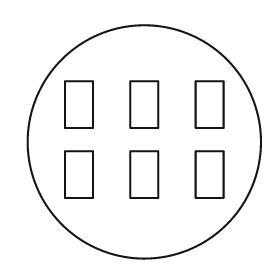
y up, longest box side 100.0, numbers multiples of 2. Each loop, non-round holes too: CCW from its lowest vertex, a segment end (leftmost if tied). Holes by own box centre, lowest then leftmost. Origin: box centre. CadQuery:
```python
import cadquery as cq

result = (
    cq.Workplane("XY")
    .moveTo(0.0, 0.0)
    .circle(50.0)
    .moveTo(-34.0, -24.0)
    .lineTo(-22.0, -24.0)
    .lineTo(-22.0, -4.0)
    .lineTo(-34.0, -4.0)
    .close()
    .moveTo(-6.0, -24.0)
    .lineTo(6.0, -24.0)
    .lineTo(6.0, -4.0)
    .lineTo(-6.0, -4.0)
    .close()
    .moveTo(22.0, -24.0)
    .lineTo(34.0, -24.0)
    .lineTo(34.0, -4.0)
    .lineTo(22.0, -4.0)
    .close()
    .moveTo(-34.0, 6.0)
    .lineTo(-22.0, 6.0)
    .lineTo(-22.0, 26.0)
    .lineTo(-34.0, 26.0)
    .close()
    .moveTo(-6.0, 6.0)
    .lineTo(6.0, 6.0)
    .lineTo(6.0, 26.0)
    .lineTo(-6.0, 26.0)
    .close()
    .moveTo(22.0, 6.0)
    .lineTo(34.0, 6.0)
    .lineTo(34.0, 26.0)
    .lineTo(22.0, 26.0)
    .close()
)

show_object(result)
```